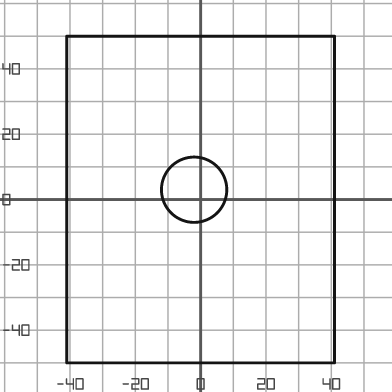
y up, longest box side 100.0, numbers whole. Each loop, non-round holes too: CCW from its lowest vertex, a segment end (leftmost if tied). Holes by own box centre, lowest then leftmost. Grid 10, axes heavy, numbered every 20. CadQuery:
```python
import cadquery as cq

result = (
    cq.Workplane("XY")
    .moveTo(-41.0, -50.0)
    .lineTo(41.0, -50.0)
    .lineTo(41.0, 50.0)
    .lineTo(-41.0, 50.0)
    .close()
    .moveTo(-2.0, 3.0)
    .circle(10.0)
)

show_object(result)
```